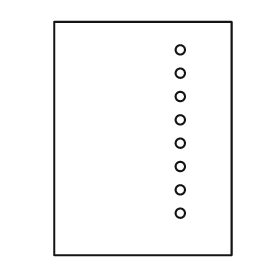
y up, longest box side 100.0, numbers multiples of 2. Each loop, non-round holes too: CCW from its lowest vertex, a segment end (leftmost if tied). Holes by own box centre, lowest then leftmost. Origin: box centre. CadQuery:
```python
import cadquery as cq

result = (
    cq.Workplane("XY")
    .moveTo(-38.0, -50.0)
    .lineTo(38.0, -50.0)
    .lineTo(38.0, 50.0)
    .lineTo(-38.0, 50.0)
    .close()
    .moveTo(16.0, -32.0)
    .circle(2.0)
    .moveTo(16.0, -22.0)
    .circle(2.0)
    .moveTo(16.0, -12.0)
    .circle(2.0)
    .moveTo(16.0, -2.0)
    .circle(2.0)
    .moveTo(16.0, 8.0)
    .circle(2.0)
    .moveTo(16.0, 18.0)
    .circle(2.0)
    .moveTo(16.0, 28.0)
    .circle(2.0)
    .moveTo(16.0, 38.0)
    .circle(2.0)
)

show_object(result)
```